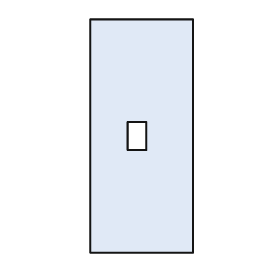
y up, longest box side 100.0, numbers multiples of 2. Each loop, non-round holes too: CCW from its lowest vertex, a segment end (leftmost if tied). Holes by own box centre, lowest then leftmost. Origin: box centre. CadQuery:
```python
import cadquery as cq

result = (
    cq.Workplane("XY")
    .moveTo(-22.0, -50.0)
    .lineTo(22.0, -50.0)
    .lineTo(22.0, 50.0)
    .lineTo(-22.0, 50.0)
    .close()
    .moveTo(-6.0, -6.0)
    .lineTo(2.0, -6.0)
    .lineTo(2.0, 6.0)
    .lineTo(-6.0, 6.0)
    .close()
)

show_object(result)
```